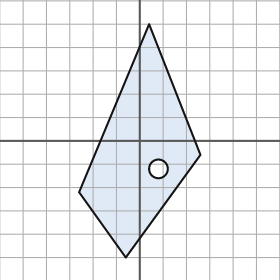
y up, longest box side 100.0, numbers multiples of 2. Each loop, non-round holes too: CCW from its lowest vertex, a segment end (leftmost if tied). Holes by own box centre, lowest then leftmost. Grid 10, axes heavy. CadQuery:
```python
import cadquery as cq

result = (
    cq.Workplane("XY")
    .moveTo(-6.0, -50.0)
    .lineTo(26.0, -6.0)
    .lineTo(4.0, 50.0)
    .lineTo(-26.0, -22.0)
    .close()
    .moveTo(8.0, -12.0)
    .circle(4.0)
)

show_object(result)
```